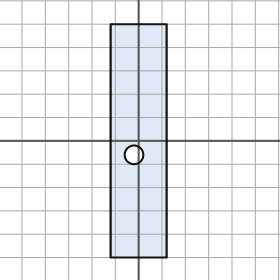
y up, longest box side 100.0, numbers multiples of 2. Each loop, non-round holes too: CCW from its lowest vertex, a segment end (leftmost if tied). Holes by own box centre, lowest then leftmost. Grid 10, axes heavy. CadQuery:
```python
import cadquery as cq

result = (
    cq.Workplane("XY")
    .moveTo(-12.0, -50.0)
    .lineTo(12.0, -50.0)
    .lineTo(12.0, 50.0)
    .lineTo(-12.0, 50.0)
    .close()
    .moveTo(-2.0, -6.0)
    .circle(4.0)
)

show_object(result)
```